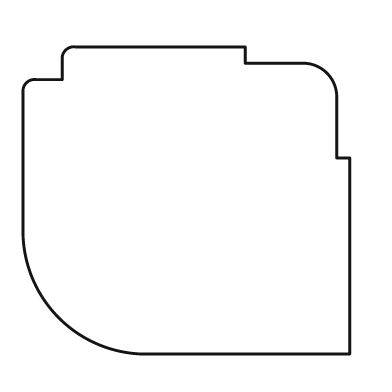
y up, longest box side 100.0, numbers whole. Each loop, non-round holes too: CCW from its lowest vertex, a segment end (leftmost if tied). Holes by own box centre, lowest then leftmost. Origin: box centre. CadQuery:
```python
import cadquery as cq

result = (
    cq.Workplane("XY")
    .moveTo(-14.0, -47.0)
    .lineTo(50.0, -47.0)
    .lineTo(50.0, 13.0)
    .lineTo(46.0, 13.0)
    .lineTo(46.0, 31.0)
    .threePointArc((43.0, 39.0), (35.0, 42.0))
    .lineTo(18.0, 42.0)
    .lineTo(18.0, 47.0)
    .lineTo(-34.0, 47.0)
    .threePointArc((-37.0, 46.0), (-38.0, 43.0))
    .lineTo(-38.0, 37.0)
    .lineTo(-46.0, 37.0)
    .threePointArc((-49.0, 36.0), (-50.0, 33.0))
    .lineTo(-50.0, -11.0)
    .threePointArc((-39.0, -36.0), (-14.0, -47.0))
    .close()
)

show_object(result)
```